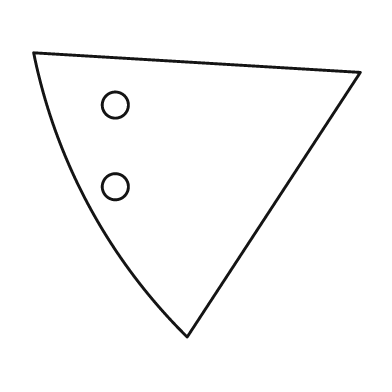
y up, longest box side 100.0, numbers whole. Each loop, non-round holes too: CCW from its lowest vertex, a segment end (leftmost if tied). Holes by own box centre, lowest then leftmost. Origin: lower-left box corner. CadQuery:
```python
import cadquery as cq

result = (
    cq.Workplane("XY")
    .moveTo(47.0, 0.0)
    .lineTo(100.0, 81.0)
    .lineTo(0.0, 87.0)
    .threePointArc((17.0, 40.0), (47.0, 0.0))
    .close()
    .moveTo(25.0, 46.0)
    .circle(4.0)
    .moveTo(25.0, 71.0)
    .circle(4.0)
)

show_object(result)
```